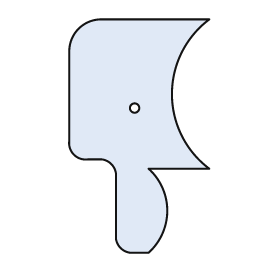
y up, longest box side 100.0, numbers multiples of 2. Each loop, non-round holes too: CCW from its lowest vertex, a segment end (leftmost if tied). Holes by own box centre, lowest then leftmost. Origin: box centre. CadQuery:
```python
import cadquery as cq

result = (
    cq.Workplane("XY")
    .moveTo(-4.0, -50.0)
    .lineTo(4.0, -50.0)
    .threePointArc((12.0, -32.0), (4.0, -14.0))
    .lineTo(30.0, -14.0)
    .threePointArc((14.0, 18.0), (30.0, 50.0))
    .lineTo(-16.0, 50.0)
    .threePointArc((-26.0, 46.0), (-30.0, 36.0))
    .lineTo(-30.0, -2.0)
    .threePointArc((-28.0, -8.0), (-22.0, -10.0))
    .lineTo(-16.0, -10.0)
    .threePointArc((-12.0, -12.0), (-10.0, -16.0))
    .lineTo(-10.0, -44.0)
    .threePointArc((-8.0, -48.0), (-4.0, -50.0))
    .close()
    .moveTo(-2.0, 12.0)
    .circle(2.0)
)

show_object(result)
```